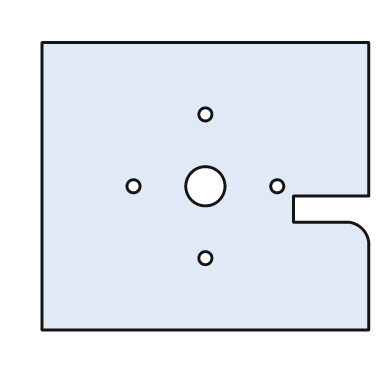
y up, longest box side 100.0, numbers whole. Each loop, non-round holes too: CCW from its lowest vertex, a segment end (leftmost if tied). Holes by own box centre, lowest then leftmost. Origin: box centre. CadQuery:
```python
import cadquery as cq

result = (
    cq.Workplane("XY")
    .moveTo(-50.0, -44.0)
    .lineTo(50.0, -44.0)
    .lineTo(50.0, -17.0)
    .threePointArc((48.0, -13.0), (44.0, -11.0))
    .lineTo(27.0, -11.0)
    .lineTo(27.0, -3.0)
    .lineTo(50.0, -3.0)
    .lineTo(50.0, 44.0)
    .lineTo(-50.0, 44.0)
    .close()
    .moveTo(0.0, -22.0)
    .circle(2.0)
    .moveTo(-22.0, 0.0)
    .circle(2.0)
    .moveTo(0.0, 0.0)
    .circle(6.0)
    .moveTo(22.0, 0.0)
    .circle(2.0)
    .moveTo(0.0, 22.0)
    .circle(2.0)
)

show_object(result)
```